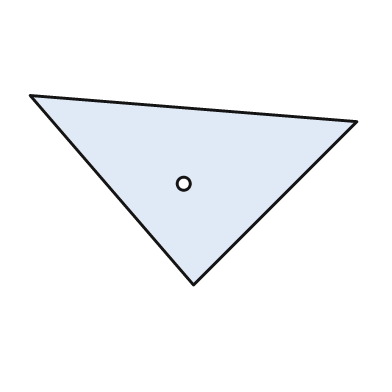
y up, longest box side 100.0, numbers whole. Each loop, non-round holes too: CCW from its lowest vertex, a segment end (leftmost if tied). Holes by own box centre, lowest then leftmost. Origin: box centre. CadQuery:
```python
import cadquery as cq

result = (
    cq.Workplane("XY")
    .moveTo(0.0, -29.0)
    .lineTo(50.0, 21.0)
    .lineTo(-50.0, 29.0)
    .close()
    .moveTo(-3.0, 2.0)
    .circle(2.0)
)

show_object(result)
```